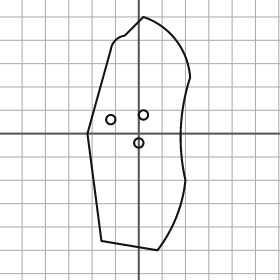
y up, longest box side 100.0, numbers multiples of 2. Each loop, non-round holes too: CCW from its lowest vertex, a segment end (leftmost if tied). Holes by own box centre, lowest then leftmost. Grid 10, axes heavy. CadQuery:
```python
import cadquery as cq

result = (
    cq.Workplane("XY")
    .moveTo(8.0, -50.0)
    .threePointArc((16.0, -36.0), (20.0, -20.0))
    .threePointArc((18.0, 2.0), (22.0, 24.0))
    .threePointArc((16.0, 40.0), (2.0, 50.0))
    .lineTo(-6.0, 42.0)
    .threePointArc((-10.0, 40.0), (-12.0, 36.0))
    .lineTo(-22.0, 0.0)
    .lineTo(-16.0, -46.0)
    .close()
    .moveTo(0.0, -4.0)
    .circle(2.0)
    .moveTo(-12.0, 6.0)
    .circle(2.0)
    .moveTo(2.0, 8.0)
    .circle(2.0)
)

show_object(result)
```